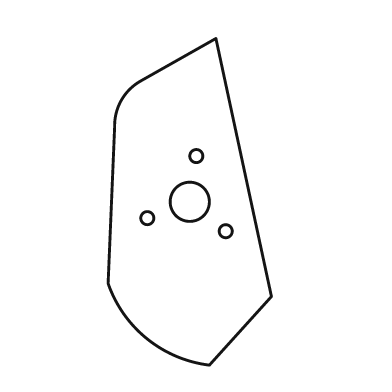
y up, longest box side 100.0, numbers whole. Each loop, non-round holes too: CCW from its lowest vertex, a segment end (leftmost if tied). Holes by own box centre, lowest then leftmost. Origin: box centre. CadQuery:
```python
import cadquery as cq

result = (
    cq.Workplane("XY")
    .moveTo(6.0, -50.0)
    .lineTo(25.0, -29.0)
    .lineTo(8.0, 50.0)
    .lineTo(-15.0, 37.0)
    .threePointArc((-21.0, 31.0), (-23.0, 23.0))
    .lineTo(-25.0, -25.0)
    .threePointArc((-13.0, -42.0), (6.0, -50.0))
    .close()
    .moveTo(11.0, -9.0)
    .circle(2.0)
    .moveTo(-13.0, -5.0)
    .circle(2.0)
    .moveTo(0.0, 0.0)
    .circle(6.0)
    .moveTo(2.0, 14.0)
    .circle(2.0)
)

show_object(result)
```